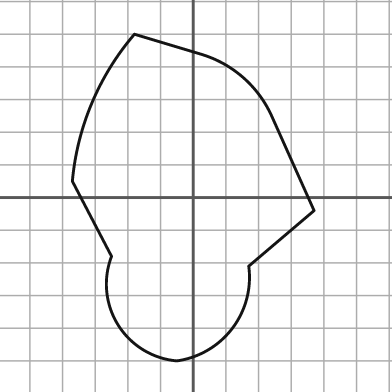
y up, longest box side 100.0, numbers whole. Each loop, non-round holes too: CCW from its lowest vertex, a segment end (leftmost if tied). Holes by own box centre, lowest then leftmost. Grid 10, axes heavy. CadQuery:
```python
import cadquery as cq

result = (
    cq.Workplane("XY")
    .moveTo(-5.0, -50.0)
    .threePointArc((12.0, -40.0), (17.0, -21.0))
    .lineTo(37.0, -4.0)
    .lineTo(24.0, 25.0)
    .threePointArc((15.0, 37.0), (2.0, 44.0))
    .lineTo(-18.0, 50.0)
    .threePointArc((-31.0, 29.0), (-37.0, 5.0))
    .lineTo(-25.0, -18.0)
    .threePointArc((-23.0, -39.0), (-5.0, -50.0))
    .close()
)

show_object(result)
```